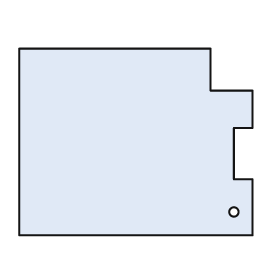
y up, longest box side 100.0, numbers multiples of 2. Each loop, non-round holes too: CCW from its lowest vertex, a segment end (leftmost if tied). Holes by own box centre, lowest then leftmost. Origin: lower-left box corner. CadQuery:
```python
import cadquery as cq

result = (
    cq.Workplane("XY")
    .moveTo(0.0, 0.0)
    .lineTo(100.0, 0.0)
    .lineTo(100.0, 24.0)
    .lineTo(92.0, 24.0)
    .lineTo(92.0, 46.0)
    .lineTo(100.0, 46.0)
    .lineTo(100.0, 62.0)
    .lineTo(82.0, 62.0)
    .lineTo(82.0, 80.0)
    .lineTo(0.0, 80.0)
    .close()
    .moveTo(92.0, 10.0)
    .circle(2.0)
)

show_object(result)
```